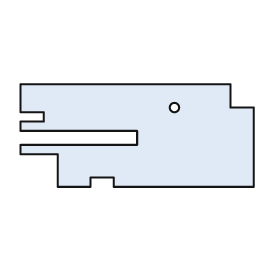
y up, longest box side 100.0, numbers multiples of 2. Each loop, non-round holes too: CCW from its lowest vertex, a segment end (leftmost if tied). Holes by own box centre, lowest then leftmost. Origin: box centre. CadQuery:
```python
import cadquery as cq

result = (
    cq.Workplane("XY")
    .moveTo(-34.0, -22.0)
    .lineTo(-20.0, -22.0)
    .lineTo(-20.0, -18.0)
    .lineTo(-10.0, -18.0)
    .lineTo(-10.0, -22.0)
    .lineTo(50.0, -22.0)
    .lineTo(50.0, 12.0)
    .lineTo(40.0, 12.0)
    .lineTo(40.0, 22.0)
    .lineTo(-50.0, 22.0)
    .lineTo(-50.0, 10.0)
    .lineTo(-40.0, 10.0)
    .lineTo(-40.0, 6.0)
    .lineTo(-50.0, 6.0)
    .lineTo(-50.0, 2.0)
    .lineTo(0.0, 2.0)
    .lineTo(0.0, -4.0)
    .lineTo(-50.0, -4.0)
    .lineTo(-50.0, -8.0)
    .lineTo(-34.0, -8.0)
    .close()
    .moveTo(16.0, 12.0)
    .circle(2.0)
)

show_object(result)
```